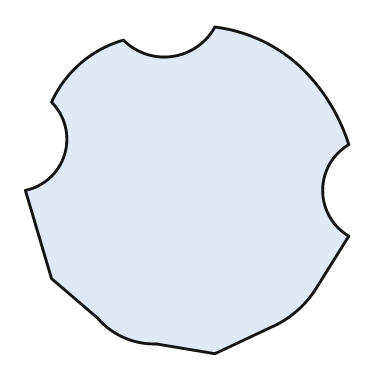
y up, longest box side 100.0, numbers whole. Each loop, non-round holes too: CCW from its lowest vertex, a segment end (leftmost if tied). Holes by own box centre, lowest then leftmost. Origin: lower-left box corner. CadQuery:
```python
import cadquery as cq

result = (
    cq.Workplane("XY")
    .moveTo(58.0, 0.0)
    .lineTo(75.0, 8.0)
    .threePointArc((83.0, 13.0), (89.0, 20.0))
    .lineTo(99.0, 36.0)
    .threePointArc((91.0, 50.0), (99.0, 64.0))
    .threePointArc((93.0, 77.0), (84.0, 88.0))
    .threePointArc((72.0, 96.0), (58.0, 100.0))
    .threePointArc((45.0, 91.0), (30.0, 96.0))
    .threePointArc((17.0, 89.0), (8.0, 77.0))
    .threePointArc((12.0, 61.0), (0.0, 50.0))
    .lineTo(8.0, 23.0)
    .lineTo(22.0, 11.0)
    .threePointArc((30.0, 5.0), (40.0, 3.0))
    .close()
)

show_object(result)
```